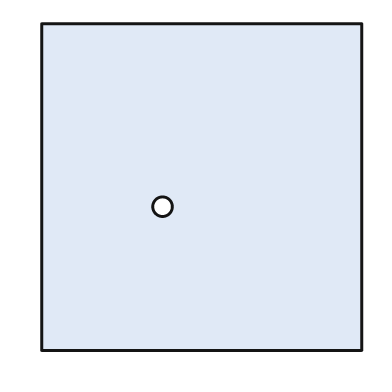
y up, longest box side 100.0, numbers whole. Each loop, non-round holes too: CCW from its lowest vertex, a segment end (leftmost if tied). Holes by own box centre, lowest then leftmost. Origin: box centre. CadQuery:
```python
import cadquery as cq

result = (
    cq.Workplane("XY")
    .moveTo(-49.0, -50.0)
    .lineTo(49.0, -50.0)
    .lineTo(49.0, 50.0)
    .lineTo(-49.0, 50.0)
    .close()
    .moveTo(-12.0, -6.0)
    .circle(3.0)
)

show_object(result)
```